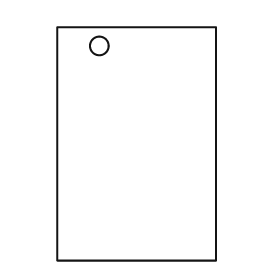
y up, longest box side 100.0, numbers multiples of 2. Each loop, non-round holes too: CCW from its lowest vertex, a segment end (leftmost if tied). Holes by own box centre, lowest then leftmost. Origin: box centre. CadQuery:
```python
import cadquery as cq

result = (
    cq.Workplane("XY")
    .moveTo(-34.0, -50.0)
    .lineTo(34.0, -50.0)
    .lineTo(34.0, 50.0)
    .lineTo(-34.0, 50.0)
    .close()
    .moveTo(-16.0, 42.0)
    .circle(4.0)
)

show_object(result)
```